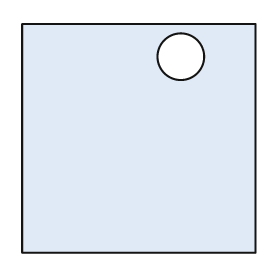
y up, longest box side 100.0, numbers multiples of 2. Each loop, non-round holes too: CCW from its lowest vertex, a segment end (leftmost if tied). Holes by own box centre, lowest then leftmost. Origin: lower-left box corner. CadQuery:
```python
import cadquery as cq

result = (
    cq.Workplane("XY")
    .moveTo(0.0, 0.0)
    .lineTo(100.0, 0.0)
    .lineTo(100.0, 98.0)
    .lineTo(0.0, 98.0)
    .close()
    .moveTo(68.0, 84.0)
    .circle(10.0)
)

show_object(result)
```